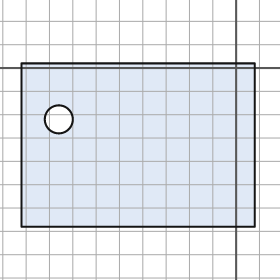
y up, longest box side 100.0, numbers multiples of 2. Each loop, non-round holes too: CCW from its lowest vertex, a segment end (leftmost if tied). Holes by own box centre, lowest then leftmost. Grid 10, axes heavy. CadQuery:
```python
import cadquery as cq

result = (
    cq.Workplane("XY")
    .moveTo(-92.0, -68.0)
    .lineTo(8.0, -68.0)
    .lineTo(8.0, 2.0)
    .lineTo(-92.0, 2.0)
    .close()
    .moveTo(-76.0, -22.0)
    .circle(6.0)
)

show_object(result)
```